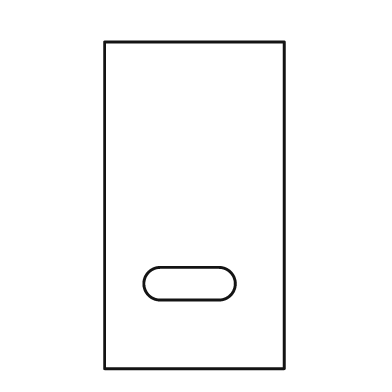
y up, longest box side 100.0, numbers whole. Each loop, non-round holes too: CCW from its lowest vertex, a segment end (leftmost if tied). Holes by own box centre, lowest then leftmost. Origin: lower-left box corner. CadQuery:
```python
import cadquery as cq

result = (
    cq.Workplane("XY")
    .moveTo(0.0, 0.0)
    .lineTo(55.0, 0.0)
    .lineTo(55.0, 100.0)
    .lineTo(0.0, 100.0)
    .close()
    .moveTo(17.0, 21.0)
    .lineTo(35.0, 21.0)
    .threePointArc((40.0, 26.0), (35.0, 31.0))
    .lineTo(17.0, 31.0)
    .threePointArc((12.0, 26.0), (17.0, 21.0))
    .close()
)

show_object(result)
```